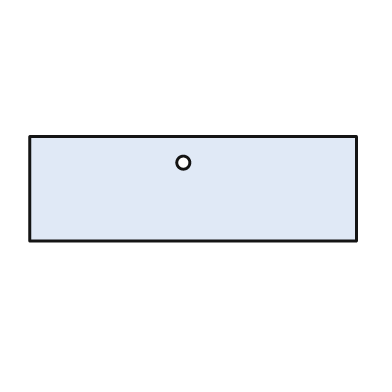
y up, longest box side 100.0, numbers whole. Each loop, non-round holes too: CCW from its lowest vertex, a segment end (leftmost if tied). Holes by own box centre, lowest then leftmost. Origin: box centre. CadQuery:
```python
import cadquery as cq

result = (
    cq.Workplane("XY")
    .moveTo(-50.0, -16.0)
    .lineTo(50.0, -16.0)
    .lineTo(50.0, 16.0)
    .lineTo(-50.0, 16.0)
    .close()
    .moveTo(-3.0, 8.0)
    .circle(2.0)
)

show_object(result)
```